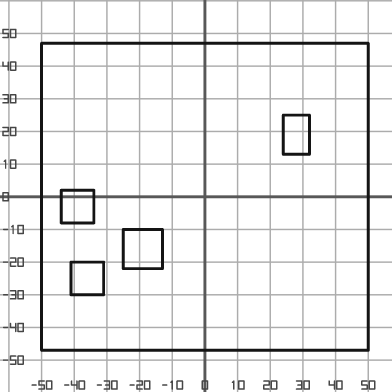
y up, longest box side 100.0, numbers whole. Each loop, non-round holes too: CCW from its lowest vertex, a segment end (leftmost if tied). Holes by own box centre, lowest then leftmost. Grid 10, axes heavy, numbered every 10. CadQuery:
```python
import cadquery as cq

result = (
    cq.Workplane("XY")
    .moveTo(-50.0, -47.0)
    .lineTo(50.0, -47.0)
    .lineTo(50.0, 47.0)
    .lineTo(-50.0, 47.0)
    .close()
    .moveTo(-41.0, -30.0)
    .lineTo(-31.0, -30.0)
    .lineTo(-31.0, -20.0)
    .lineTo(-41.0, -20.0)
    .close()
    .moveTo(-25.0, -22.0)
    .lineTo(-13.0, -22.0)
    .lineTo(-13.0, -10.0)
    .lineTo(-25.0, -10.0)
    .close()
    .moveTo(-44.0, -8.0)
    .lineTo(-34.0, -8.0)
    .lineTo(-34.0, 2.0)
    .lineTo(-44.0, 2.0)
    .close()
    .moveTo(24.0, 13.0)
    .lineTo(32.0, 13.0)
    .lineTo(32.0, 25.0)
    .lineTo(24.0, 25.0)
    .close()
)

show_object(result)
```